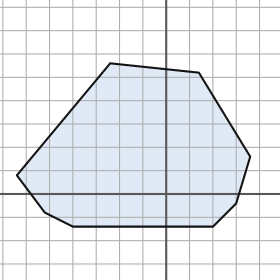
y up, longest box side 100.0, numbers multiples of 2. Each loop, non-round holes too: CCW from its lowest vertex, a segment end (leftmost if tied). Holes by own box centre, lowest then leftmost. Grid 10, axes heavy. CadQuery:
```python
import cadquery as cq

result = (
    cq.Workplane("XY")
    .moveTo(-40.0, -14.0)
    .lineTo(20.0, -14.0)
    .lineTo(30.0, -4.0)
    .lineTo(36.0, 16.0)
    .lineTo(14.0, 52.0)
    .lineTo(-24.0, 56.0)
    .lineTo(-64.0, 8.0)
    .lineTo(-52.0, -8.0)
    .close()
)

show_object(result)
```